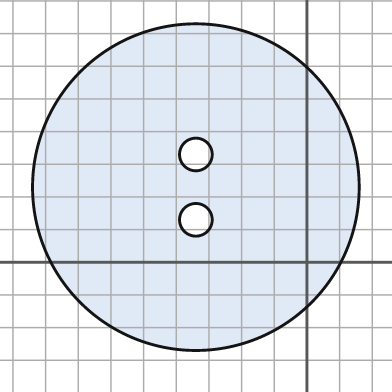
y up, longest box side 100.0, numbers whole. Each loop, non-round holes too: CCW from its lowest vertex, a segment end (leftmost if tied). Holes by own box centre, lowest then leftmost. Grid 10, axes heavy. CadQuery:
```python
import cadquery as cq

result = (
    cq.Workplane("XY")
    .moveTo(-34.0, 23.0)
    .circle(50.0)
    .moveTo(-34.0, 13.0)
    .circle(5.0)
    .moveTo(-34.0, 33.0)
    .circle(5.0)
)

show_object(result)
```